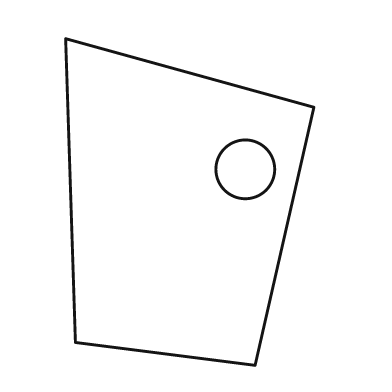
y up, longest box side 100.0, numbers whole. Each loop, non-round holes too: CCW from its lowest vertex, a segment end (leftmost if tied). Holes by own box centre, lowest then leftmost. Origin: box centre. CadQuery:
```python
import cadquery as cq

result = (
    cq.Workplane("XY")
    .moveTo(20.0, -50.0)
    .lineTo(38.0, 29.0)
    .lineTo(-38.0, 50.0)
    .lineTo(-35.0, -43.0)
    .close()
    .moveTo(17.0, 10.0)
    .circle(9.0)
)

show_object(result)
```